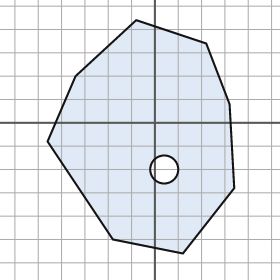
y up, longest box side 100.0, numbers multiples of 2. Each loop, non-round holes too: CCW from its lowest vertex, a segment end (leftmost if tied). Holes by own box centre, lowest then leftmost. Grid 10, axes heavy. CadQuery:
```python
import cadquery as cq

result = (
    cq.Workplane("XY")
    .moveTo(12.0, -56.0)
    .lineTo(34.0, -28.0)
    .lineTo(32.0, 8.0)
    .lineTo(22.0, 34.0)
    .lineTo(-8.0, 44.0)
    .lineTo(-34.0, 20.0)
    .lineTo(-46.0, -8.0)
    .lineTo(-18.0, -50.0)
    .close()
    .moveTo(4.0, -20.0)
    .circle(6.0)
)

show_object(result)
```